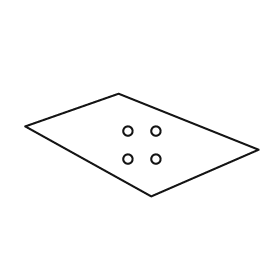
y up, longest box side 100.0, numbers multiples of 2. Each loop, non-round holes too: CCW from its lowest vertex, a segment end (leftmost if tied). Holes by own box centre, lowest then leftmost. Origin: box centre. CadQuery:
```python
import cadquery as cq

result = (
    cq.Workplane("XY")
    .moveTo(4.0, -22.0)
    .lineTo(50.0, -2.0)
    .lineTo(-10.0, 22.0)
    .lineTo(-50.0, 8.0)
    .close()
    .moveTo(-6.0, -6.0)
    .circle(2.0)
    .moveTo(6.0, -6.0)
    .circle(2.0)
    .moveTo(-6.0, 6.0)
    .circle(2.0)
    .moveTo(6.0, 6.0)
    .circle(2.0)
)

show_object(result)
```